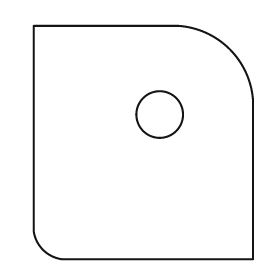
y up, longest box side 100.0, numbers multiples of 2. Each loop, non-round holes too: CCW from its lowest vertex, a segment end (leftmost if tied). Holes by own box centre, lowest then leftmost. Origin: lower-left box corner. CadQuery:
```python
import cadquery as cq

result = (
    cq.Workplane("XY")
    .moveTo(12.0, 0.0)
    .lineTo(94.0, 0.0)
    .lineTo(94.0, 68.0)
    .threePointArc((84.0, 90.0), (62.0, 100.0))
    .lineTo(0.0, 100.0)
    .lineTo(0.0, 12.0)
    .threePointArc((4.0, 4.0), (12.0, 0.0))
    .close()
    .moveTo(54.0, 62.0)
    .circle(10.0)
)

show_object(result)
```